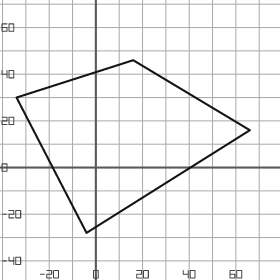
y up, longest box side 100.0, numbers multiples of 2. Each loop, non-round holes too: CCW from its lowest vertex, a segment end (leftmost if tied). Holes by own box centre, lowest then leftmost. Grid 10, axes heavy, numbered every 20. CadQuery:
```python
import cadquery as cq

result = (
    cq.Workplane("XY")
    .moveTo(-4.0, -28.0)
    .lineTo(66.0, 16.0)
    .lineTo(16.0, 46.0)
    .lineTo(-34.0, 30.0)
    .close()
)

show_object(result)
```